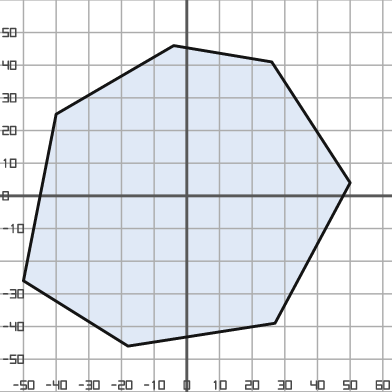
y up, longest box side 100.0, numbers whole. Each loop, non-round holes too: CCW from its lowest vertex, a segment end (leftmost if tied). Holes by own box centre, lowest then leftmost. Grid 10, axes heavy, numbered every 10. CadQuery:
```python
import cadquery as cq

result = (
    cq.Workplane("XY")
    .moveTo(-18.0, -46.0)
    .lineTo(27.0, -39.0)
    .lineTo(50.0, 4.0)
    .lineTo(26.0, 41.0)
    .lineTo(-4.0, 46.0)
    .lineTo(-40.0, 25.0)
    .lineTo(-50.0, -26.0)
    .close()
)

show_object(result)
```